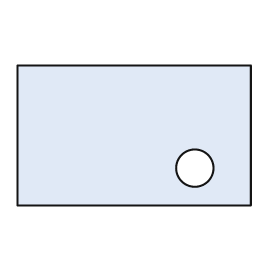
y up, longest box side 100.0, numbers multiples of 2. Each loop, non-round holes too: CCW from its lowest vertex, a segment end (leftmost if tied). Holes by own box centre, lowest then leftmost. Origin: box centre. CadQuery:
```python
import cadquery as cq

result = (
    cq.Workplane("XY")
    .moveTo(-50.0, -30.0)
    .lineTo(50.0, -30.0)
    .lineTo(50.0, 30.0)
    .lineTo(-50.0, 30.0)
    .close()
    .moveTo(26.0, -14.0)
    .circle(8.0)
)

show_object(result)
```